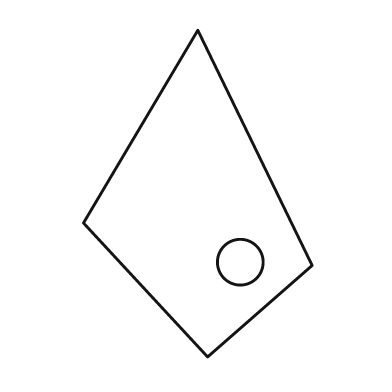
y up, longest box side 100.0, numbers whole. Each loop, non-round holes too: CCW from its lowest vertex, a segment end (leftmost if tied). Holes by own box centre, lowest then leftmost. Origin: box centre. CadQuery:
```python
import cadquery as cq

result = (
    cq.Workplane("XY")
    .moveTo(3.0, -50.0)
    .lineTo(35.0, -22.0)
    .lineTo(0.0, 50.0)
    .lineTo(-35.0, -9.0)
    .close()
    .moveTo(13.0, -21.0)
    .circle(7.0)
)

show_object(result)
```